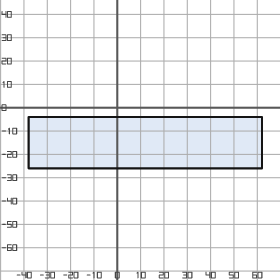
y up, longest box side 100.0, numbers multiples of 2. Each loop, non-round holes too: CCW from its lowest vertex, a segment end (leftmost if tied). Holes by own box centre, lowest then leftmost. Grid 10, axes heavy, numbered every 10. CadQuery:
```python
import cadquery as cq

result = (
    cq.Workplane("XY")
    .moveTo(-38.0, -26.0)
    .lineTo(62.0, -26.0)
    .lineTo(62.0, -4.0)
    .lineTo(-38.0, -4.0)
    .close()
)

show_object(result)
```